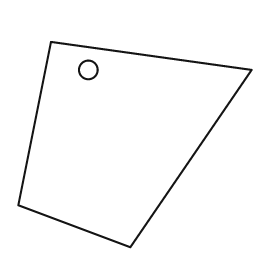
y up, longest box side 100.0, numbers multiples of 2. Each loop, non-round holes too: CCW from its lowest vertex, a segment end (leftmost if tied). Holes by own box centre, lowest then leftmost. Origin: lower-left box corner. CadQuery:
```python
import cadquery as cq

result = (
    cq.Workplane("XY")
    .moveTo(48.0, 0.0)
    .lineTo(100.0, 76.0)
    .lineTo(14.0, 88.0)
    .lineTo(0.0, 18.0)
    .close()
    .moveTo(30.0, 76.0)
    .circle(4.0)
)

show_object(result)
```